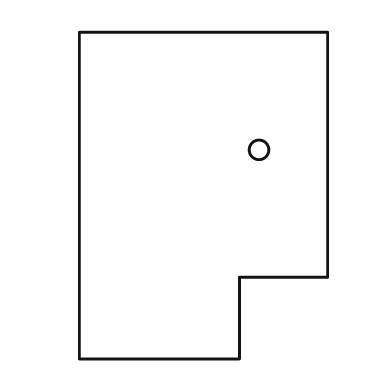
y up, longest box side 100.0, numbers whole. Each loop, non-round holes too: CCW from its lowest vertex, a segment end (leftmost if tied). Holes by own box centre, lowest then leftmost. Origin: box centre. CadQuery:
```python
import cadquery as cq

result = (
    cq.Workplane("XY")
    .moveTo(-38.0, -50.0)
    .lineTo(11.0, -50.0)
    .lineTo(11.0, -25.0)
    .lineTo(38.0, -25.0)
    .lineTo(38.0, 50.0)
    .lineTo(-38.0, 50.0)
    .close()
    .moveTo(17.0, 14.0)
    .circle(3.0)
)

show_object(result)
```